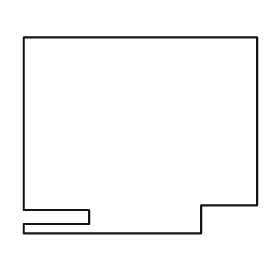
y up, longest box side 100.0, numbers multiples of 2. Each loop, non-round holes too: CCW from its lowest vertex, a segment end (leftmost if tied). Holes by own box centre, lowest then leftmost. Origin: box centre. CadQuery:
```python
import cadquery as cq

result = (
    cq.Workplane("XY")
    .moveTo(-50.0, -42.0)
    .lineTo(26.0, -42.0)
    .lineTo(26.0, -30.0)
    .lineTo(50.0, -30.0)
    .lineTo(50.0, 42.0)
    .lineTo(-50.0, 42.0)
    .lineTo(-50.0, -32.0)
    .lineTo(-22.0, -32.0)
    .lineTo(-22.0, -38.0)
    .lineTo(-50.0, -38.0)
    .close()
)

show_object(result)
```